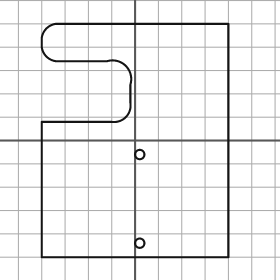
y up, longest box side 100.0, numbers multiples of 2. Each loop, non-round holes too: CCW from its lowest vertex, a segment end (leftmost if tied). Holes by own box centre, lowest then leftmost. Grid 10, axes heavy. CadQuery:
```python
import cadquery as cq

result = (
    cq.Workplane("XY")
    .moveTo(-40.0, -50.0)
    .lineTo(40.0, -50.0)
    .lineTo(40.0, 50.0)
    .lineTo(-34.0, 50.0)
    .threePointArc((-38.0, 48.0), (-40.0, 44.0))
    .lineTo(-40.0, 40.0)
    .threePointArc((-38.0, 36.0), (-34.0, 34.0))
    .lineTo(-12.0, 34.0)
    .threePointArc((-4.0, 32.0), (-2.0, 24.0))
    .lineTo(-2.0, 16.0)
    .threePointArc((-4.0, 10.0), (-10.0, 8.0))
    .lineTo(-40.0, 8.0)
    .close()
    .moveTo(2.0, -44.0)
    .circle(2.0)
    .moveTo(2.0, -6.0)
    .circle(2.0)
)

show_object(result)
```